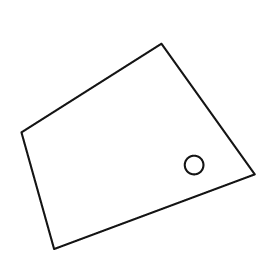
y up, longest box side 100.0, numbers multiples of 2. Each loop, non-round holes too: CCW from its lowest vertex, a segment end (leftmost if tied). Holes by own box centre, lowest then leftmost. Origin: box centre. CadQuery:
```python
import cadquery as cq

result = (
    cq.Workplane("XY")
    .moveTo(-36.0, -44.0)
    .lineTo(50.0, -12.0)
    .lineTo(10.0, 44.0)
    .lineTo(-50.0, 6.0)
    .close()
    .moveTo(24.0, -8.0)
    .circle(4.0)
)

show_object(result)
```